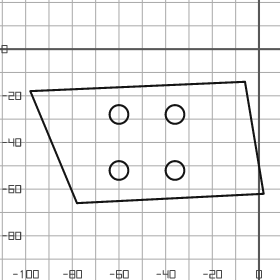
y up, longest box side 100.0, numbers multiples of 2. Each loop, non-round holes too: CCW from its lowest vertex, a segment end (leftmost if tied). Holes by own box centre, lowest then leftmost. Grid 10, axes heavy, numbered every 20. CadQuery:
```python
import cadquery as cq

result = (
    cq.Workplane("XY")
    .moveTo(-78.0, -66.0)
    .lineTo(2.0, -62.0)
    .lineTo(-6.0, -14.0)
    .lineTo(-98.0, -18.0)
    .close()
    .moveTo(-60.0, -52.0)
    .circle(4.0)
    .moveTo(-36.0, -52.0)
    .circle(4.0)
    .moveTo(-60.0, -28.0)
    .circle(4.0)
    .moveTo(-36.0, -28.0)
    .circle(4.0)
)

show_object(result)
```